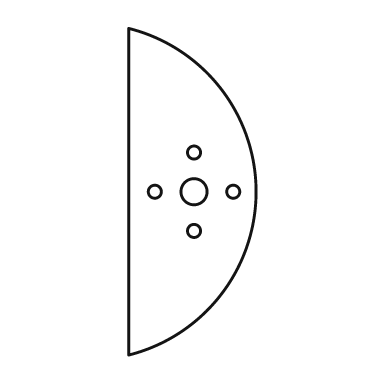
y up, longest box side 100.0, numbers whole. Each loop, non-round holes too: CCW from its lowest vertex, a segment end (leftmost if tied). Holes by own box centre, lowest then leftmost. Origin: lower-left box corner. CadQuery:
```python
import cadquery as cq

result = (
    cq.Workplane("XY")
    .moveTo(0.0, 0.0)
    .threePointArc((39.0, 50.0), (0.0, 100.0))
    .close()
    .moveTo(20.0, 38.0)
    .circle(2.0)
    .moveTo(8.0, 50.0)
    .circle(2.0)
    .moveTo(20.0, 50.0)
    .circle(4.0)
    .moveTo(32.0, 50.0)
    .circle(2.0)
    .moveTo(20.0, 62.0)
    .circle(2.0)
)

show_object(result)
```